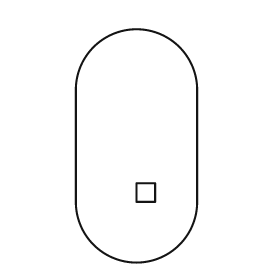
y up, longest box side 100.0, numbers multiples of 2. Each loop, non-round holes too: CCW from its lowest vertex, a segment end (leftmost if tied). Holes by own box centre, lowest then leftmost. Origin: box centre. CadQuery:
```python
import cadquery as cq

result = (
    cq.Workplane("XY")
    .moveTo(-26.0, -24.0)
    .threePointArc((0.0, -50.0), (26.0, -24.0))
    .lineTo(26.0, 24.0)
    .threePointArc((0.0, 50.0), (-26.0, 24.0))
    .close()
    .moveTo(0.0, -24.0)
    .lineTo(8.0, -24.0)
    .lineTo(8.0, -16.0)
    .lineTo(0.0, -16.0)
    .close()
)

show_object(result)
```